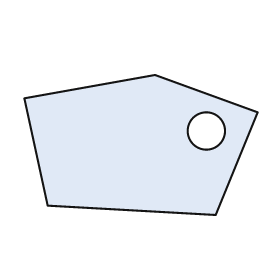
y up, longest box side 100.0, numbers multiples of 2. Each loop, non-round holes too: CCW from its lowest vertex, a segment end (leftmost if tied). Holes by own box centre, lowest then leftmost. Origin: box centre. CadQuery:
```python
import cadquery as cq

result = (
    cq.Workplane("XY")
    .moveTo(32.0, -30.0)
    .lineTo(50.0, 14.0)
    .lineTo(6.0, 30.0)
    .lineTo(-50.0, 20.0)
    .lineTo(-40.0, -26.0)
    .close()
    .moveTo(28.0, 6.0)
    .circle(8.0)
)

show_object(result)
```